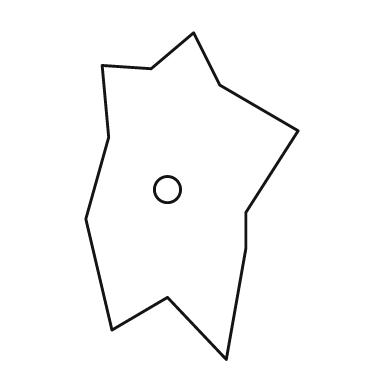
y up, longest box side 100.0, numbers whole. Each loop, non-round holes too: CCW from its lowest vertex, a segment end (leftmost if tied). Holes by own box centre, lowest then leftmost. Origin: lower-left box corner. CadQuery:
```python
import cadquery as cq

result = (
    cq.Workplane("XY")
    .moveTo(43.0, 0.0)
    .lineTo(49.0, 34.0)
    .lineTo(49.0, 45.0)
    .lineTo(65.0, 70.0)
    .lineTo(41.0, 84.0)
    .lineTo(33.0, 100.0)
    .lineTo(20.0, 89.0)
    .lineTo(5.0, 90.0)
    .lineTo(7.0, 68.0)
    .lineTo(0.0, 43.0)
    .lineTo(8.0, 9.0)
    .lineTo(25.0, 19.0)
    .close()
    .moveTo(25.0, 52.0)
    .circle(4.0)
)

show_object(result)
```